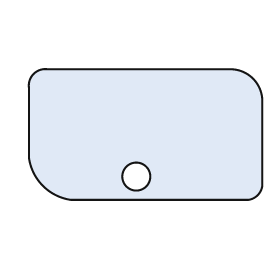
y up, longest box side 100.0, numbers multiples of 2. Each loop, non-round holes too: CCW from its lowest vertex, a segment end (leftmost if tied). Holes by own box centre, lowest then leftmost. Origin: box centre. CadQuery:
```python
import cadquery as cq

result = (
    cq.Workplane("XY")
    .moveTo(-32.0, -28.0)
    .lineTo(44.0, -28.0)
    .threePointArc((48.0, -26.0), (50.0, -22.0))
    .lineTo(50.0, 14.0)
    .threePointArc((46.0, 24.0), (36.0, 28.0))
    .lineTo(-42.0, 28.0)
    .threePointArc((-48.0, 26.0), (-50.0, 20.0))
    .lineTo(-50.0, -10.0)
    .threePointArc((-44.0, -22.0), (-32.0, -28.0))
    .close()
    .moveTo(-4.0, -18.0)
    .circle(6.0)
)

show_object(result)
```